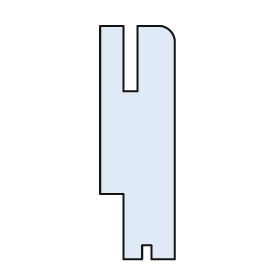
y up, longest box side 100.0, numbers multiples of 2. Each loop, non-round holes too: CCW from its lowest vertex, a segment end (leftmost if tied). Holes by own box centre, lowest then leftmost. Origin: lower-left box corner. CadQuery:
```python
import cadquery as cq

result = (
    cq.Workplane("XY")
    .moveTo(10.0, 0.0)
    .lineTo(18.0, 0.0)
    .lineTo(18.0, 6.0)
    .lineTo(22.0, 6.0)
    .lineTo(22.0, 0.0)
    .lineTo(32.0, 0.0)
    .lineTo(32.0, 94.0)
    .threePointArc((30.0, 98.0), (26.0, 100.0))
    .lineTo(16.0, 100.0)
    .lineTo(16.0, 72.0)
    .lineTo(10.0, 72.0)
    .lineTo(10.0, 100.0)
    .lineTo(0.0, 100.0)
    .lineTo(0.0, 28.0)
    .lineTo(10.0, 28.0)
    .close()
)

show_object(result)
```